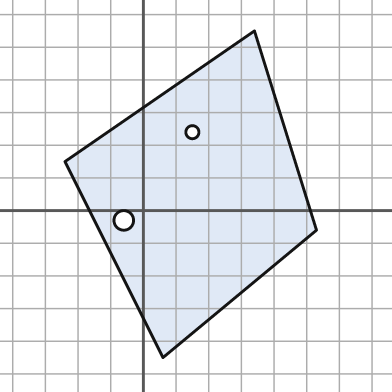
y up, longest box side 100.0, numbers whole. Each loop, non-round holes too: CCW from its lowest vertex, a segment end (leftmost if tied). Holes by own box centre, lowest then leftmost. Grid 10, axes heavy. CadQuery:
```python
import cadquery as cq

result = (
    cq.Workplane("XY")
    .moveTo(6.0, -45.0)
    .lineTo(53.0, -6.0)
    .lineTo(34.0, 55.0)
    .lineTo(-24.0, 15.0)
    .close()
    .moveTo(-6.0, -3.0)
    .circle(3.0)
    .moveTo(15.0, 24.0)
    .circle(2.0)
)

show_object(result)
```